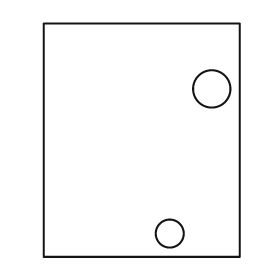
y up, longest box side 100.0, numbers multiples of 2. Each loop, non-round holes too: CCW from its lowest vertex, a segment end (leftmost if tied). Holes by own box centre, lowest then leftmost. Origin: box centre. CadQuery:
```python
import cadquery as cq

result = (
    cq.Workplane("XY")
    .moveTo(-42.0, -50.0)
    .lineTo(42.0, -50.0)
    .lineTo(42.0, 50.0)
    .lineTo(-42.0, 50.0)
    .close()
    .moveTo(12.0, -40.0)
    .circle(6.0)
    .moveTo(30.0, 22.0)
    .circle(8.0)
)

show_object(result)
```